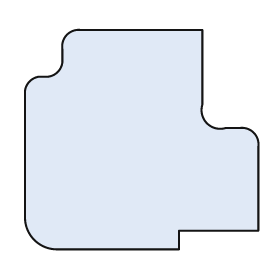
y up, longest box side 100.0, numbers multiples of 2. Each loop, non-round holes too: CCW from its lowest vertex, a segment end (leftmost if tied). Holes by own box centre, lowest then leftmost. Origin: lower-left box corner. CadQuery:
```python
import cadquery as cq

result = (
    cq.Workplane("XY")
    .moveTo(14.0, 0.0)
    .lineTo(66.0, 0.0)
    .lineTo(66.0, 8.0)
    .lineTo(100.0, 8.0)
    .lineTo(100.0, 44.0)
    .threePointArc((98.0, 50.0), (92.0, 52.0))
    .lineTo(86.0, 52.0)
    .threePointArc((78.0, 54.0), (76.0, 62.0))
    .lineTo(76.0, 94.0)
    .lineTo(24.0, 94.0)
    .threePointArc((18.0, 92.0), (16.0, 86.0))
    .lineTo(16.0, 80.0)
    .threePointArc((14.0, 76.0), (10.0, 74.0))
    .lineTo(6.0, 74.0)
    .threePointArc((2.0, 72.0), (0.0, 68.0))
    .lineTo(0.0, 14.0)
    .threePointArc((4.0, 4.0), (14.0, 0.0))
    .close()
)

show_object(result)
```